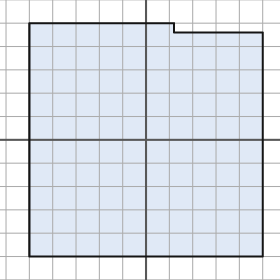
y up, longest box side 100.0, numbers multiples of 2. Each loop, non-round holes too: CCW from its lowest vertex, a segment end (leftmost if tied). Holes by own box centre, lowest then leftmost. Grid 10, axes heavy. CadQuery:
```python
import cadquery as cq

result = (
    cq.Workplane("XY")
    .moveTo(-50.0, -50.0)
    .lineTo(50.0, -50.0)
    .lineTo(50.0, 46.0)
    .lineTo(12.0, 46.0)
    .lineTo(12.0, 50.0)
    .lineTo(-50.0, 50.0)
    .close()
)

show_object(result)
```